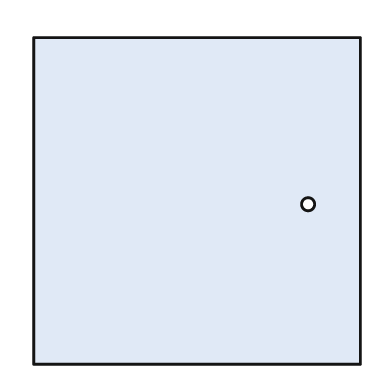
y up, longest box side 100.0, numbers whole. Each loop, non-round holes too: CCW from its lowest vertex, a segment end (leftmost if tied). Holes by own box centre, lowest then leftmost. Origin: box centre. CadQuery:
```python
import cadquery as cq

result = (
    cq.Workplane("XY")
    .moveTo(-50.0, -50.0)
    .lineTo(50.0, -50.0)
    .lineTo(50.0, 50.0)
    .lineTo(-50.0, 50.0)
    .close()
    .moveTo(34.0, -1.0)
    .circle(2.0)
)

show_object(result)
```